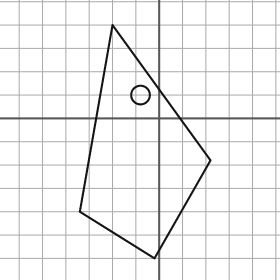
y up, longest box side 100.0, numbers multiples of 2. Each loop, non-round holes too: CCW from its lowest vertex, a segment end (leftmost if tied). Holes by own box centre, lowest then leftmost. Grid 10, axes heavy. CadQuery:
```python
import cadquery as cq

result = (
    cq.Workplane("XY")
    .moveTo(-2.0, -60.0)
    .lineTo(22.0, -18.0)
    .lineTo(-20.0, 40.0)
    .lineTo(-34.0, -40.0)
    .close()
    .moveTo(-8.0, 10.0)
    .circle(4.0)
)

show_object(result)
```